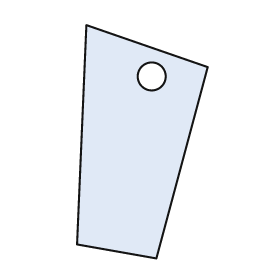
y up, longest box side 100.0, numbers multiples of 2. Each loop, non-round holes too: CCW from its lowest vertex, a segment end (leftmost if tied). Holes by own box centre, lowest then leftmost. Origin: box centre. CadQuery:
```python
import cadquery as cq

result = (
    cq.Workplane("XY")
    .moveTo(6.0, -50.0)
    .lineTo(28.0, 32.0)
    .lineTo(-24.0, 50.0)
    .lineTo(-28.0, -44.0)
    .close()
    .moveTo(4.0, 28.0)
    .circle(6.0)
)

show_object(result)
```